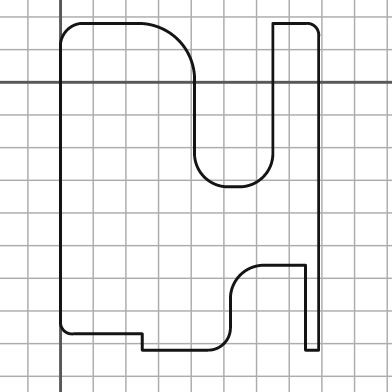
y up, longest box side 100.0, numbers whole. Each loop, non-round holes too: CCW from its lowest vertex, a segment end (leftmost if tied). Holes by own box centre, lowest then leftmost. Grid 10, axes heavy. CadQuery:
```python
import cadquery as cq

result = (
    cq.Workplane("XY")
    .moveTo(25.0, -82.0)
    .lineTo(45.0, -82.0)
    .threePointArc((50.0, -80.0), (52.0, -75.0))
    .lineTo(52.0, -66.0)
    .threePointArc((55.0, -59.0), (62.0, -56.0))
    .lineTo(75.0, -56.0)
    .lineTo(75.0, -82.0)
    .lineTo(79.0, -82.0)
    .lineTo(79.0, 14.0)
    .threePointArc((78.0, 17.0), (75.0, 18.0))
    .lineTo(65.0, 18.0)
    .lineTo(65.0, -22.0)
    .threePointArc((62.0, -29.0), (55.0, -32.0))
    .lineTo(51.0, -32.0)
    .threePointArc((44.0, -29.0), (41.0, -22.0))
    .lineTo(41.0, 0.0)
    .threePointArc((36.0, 13.0), (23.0, 18.0))
    .lineTo(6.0, 18.0)
    .threePointArc((2.0, 16.0), (0.0, 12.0))
    .lineTo(0.0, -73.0)
    .threePointArc((1.0, -76.0), (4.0, -77.0))
    .lineTo(25.0, -77.0)
    .close()
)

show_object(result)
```